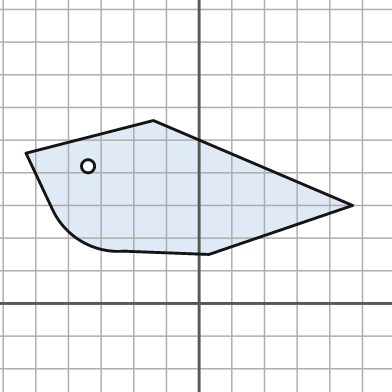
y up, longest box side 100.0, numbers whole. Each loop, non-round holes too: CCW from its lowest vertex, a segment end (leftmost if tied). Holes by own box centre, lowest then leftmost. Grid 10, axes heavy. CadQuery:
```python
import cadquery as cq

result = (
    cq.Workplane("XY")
    .moveTo(3.0, 15.0)
    .lineTo(47.0, 30.0)
    .lineTo(-14.0, 56.0)
    .lineTo(-53.0, 46.0)
    .lineTo(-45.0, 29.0)
    .threePointArc((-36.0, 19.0), (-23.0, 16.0))
    .close()
    .moveTo(-34.0, 42.0)
    .circle(2.0)
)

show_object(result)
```